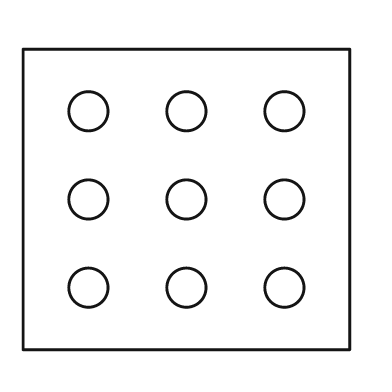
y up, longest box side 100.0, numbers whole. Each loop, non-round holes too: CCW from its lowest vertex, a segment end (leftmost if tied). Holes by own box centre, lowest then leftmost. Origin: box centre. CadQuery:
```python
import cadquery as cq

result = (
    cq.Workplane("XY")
    .moveTo(-50.0, -46.0)
    .lineTo(50.0, -46.0)
    .lineTo(50.0, 46.0)
    .lineTo(-50.0, 46.0)
    .close()
    .moveTo(-30.0, -27.0)
    .circle(6.0)
    .moveTo(0.0, -27.0)
    .circle(6.0)
    .moveTo(30.0, -27.0)
    .circle(6.0)
    .moveTo(-30.0, 0.0)
    .circle(6.0)
    .moveTo(0.0, 0.0)
    .circle(6.0)
    .moveTo(30.0, 0.0)
    .circle(6.0)
    .moveTo(-30.0, 27.0)
    .circle(6.0)
    .moveTo(0.0, 27.0)
    .circle(6.0)
    .moveTo(30.0, 27.0)
    .circle(6.0)
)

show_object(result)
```